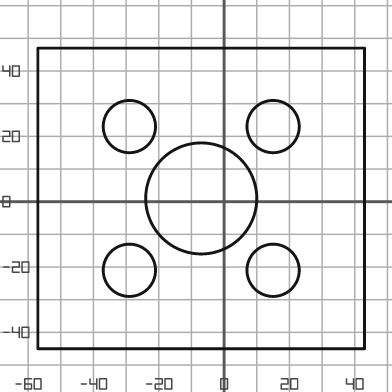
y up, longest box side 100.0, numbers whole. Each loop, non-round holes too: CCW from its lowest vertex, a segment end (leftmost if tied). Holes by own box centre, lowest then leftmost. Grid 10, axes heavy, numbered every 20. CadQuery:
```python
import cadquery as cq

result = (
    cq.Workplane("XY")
    .moveTo(-57.0, -45.0)
    .lineTo(43.0, -45.0)
    .lineTo(43.0, 47.0)
    .lineTo(-57.0, 47.0)
    .close()
    .moveTo(-29.0, -21.0)
    .circle(8.0)
    .moveTo(15.0, -21.0)
    .circle(8.0)
    .moveTo(-7.0, 1.0)
    .circle(17.0)
    .moveTo(-29.0, 23.0)
    .circle(8.0)
    .moveTo(15.0, 23.0)
    .circle(8.0)
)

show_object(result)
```